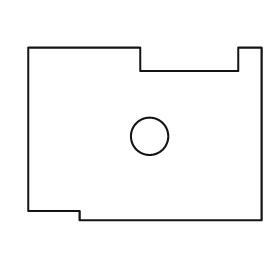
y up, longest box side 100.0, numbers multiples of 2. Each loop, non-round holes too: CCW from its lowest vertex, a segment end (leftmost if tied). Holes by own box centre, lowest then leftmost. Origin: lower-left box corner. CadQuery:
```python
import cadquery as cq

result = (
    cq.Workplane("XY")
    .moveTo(22.0, 0.0)
    .lineTo(100.0, 0.0)
    .lineTo(100.0, 74.0)
    .lineTo(90.0, 74.0)
    .lineTo(90.0, 64.0)
    .lineTo(48.0, 64.0)
    .lineTo(48.0, 74.0)
    .lineTo(0.0, 74.0)
    .lineTo(0.0, 4.0)
    .lineTo(22.0, 4.0)
    .close()
    .moveTo(52.0, 36.0)
    .circle(8.0)
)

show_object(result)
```